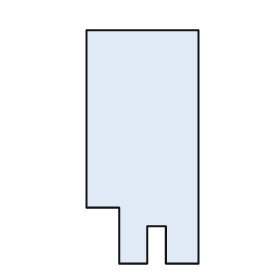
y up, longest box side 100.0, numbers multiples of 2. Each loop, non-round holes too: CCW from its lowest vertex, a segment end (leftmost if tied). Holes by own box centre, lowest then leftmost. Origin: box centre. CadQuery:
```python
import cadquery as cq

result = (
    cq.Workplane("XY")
    .moveTo(-10.0, -50.0)
    .lineTo(2.0, -50.0)
    .lineTo(2.0, -34.0)
    .lineTo(10.0, -34.0)
    .lineTo(10.0, -50.0)
    .lineTo(24.0, -50.0)
    .lineTo(24.0, 50.0)
    .lineTo(-24.0, 50.0)
    .lineTo(-24.0, -26.0)
    .lineTo(-10.0, -26.0)
    .close()
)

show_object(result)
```